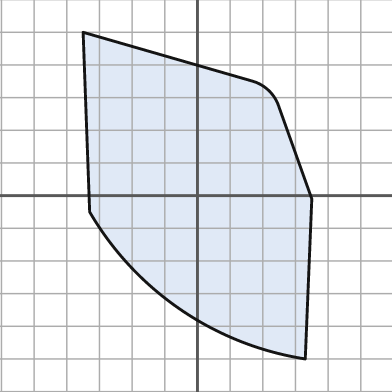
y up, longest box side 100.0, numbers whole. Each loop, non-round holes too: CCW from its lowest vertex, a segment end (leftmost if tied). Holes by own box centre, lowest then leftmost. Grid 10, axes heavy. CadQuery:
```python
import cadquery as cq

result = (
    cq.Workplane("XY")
    .moveTo(33.0, -50.0)
    .lineTo(35.0, -1.0)
    .lineTo(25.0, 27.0)
    .threePointArc((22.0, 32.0), (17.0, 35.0))
    .lineTo(-35.0, 50.0)
    .lineTo(-33.0, -5.0)
    .threePointArc((-5.0, -35.0), (33.0, -50.0))
    .close()
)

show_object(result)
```